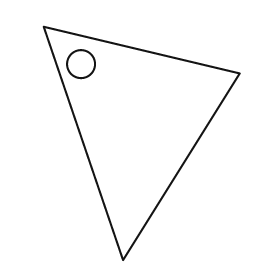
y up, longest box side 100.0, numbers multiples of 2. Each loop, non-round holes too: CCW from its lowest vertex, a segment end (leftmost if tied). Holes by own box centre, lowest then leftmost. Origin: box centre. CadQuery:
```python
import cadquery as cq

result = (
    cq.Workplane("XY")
    .moveTo(-8.0, -50.0)
    .lineTo(42.0, 30.0)
    .lineTo(-42.0, 50.0)
    .close()
    .moveTo(-26.0, 34.0)
    .circle(6.0)
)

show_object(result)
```